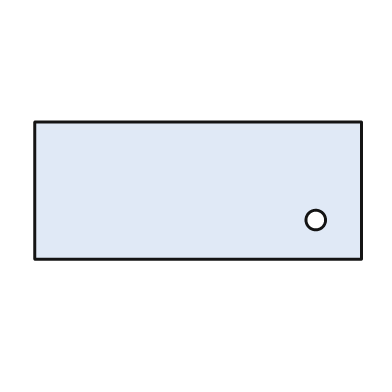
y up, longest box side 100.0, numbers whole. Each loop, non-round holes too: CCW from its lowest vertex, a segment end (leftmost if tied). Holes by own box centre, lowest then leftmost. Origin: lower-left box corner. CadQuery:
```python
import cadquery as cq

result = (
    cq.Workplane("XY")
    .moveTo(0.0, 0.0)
    .lineTo(100.0, 0.0)
    .lineTo(100.0, 42.0)
    .lineTo(0.0, 42.0)
    .close()
    .moveTo(86.0, 12.0)
    .circle(3.0)
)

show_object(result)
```